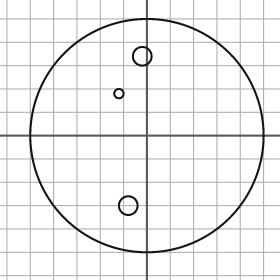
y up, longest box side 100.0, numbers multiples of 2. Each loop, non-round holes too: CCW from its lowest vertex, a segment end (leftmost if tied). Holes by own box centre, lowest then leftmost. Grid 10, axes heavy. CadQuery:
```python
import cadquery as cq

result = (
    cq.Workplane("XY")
    .moveTo(0.0, 0.0)
    .circle(50.0)
    .moveTo(-8.0, -30.0)
    .circle(4.0)
    .moveTo(-12.0, 18.0)
    .circle(2.0)
    .moveTo(-2.0, 34.0)
    .circle(4.0)
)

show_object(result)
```